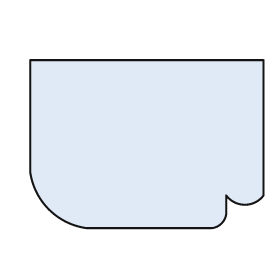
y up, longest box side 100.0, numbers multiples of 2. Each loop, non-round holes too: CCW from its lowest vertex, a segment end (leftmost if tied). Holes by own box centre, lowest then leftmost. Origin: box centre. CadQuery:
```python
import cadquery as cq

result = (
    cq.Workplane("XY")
    .moveTo(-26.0, -36.0)
    .lineTo(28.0, -36.0)
    .threePointArc((32.0, -34.0), (34.0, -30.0))
    .lineTo(34.0, -22.0)
    .threePointArc((42.0, -26.0), (50.0, -22.0))
    .lineTo(50.0, 36.0)
    .lineTo(-50.0, 36.0)
    .lineTo(-50.0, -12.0)
    .threePointArc((-42.0, -28.0), (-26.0, -36.0))
    .close()
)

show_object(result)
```